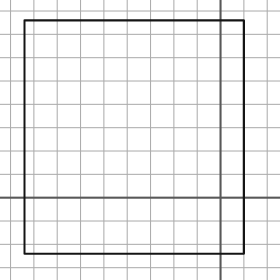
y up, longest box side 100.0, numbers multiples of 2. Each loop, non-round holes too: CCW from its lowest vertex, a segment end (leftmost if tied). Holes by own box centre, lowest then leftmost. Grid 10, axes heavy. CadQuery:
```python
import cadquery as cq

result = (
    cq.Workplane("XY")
    .moveTo(-84.0, -24.0)
    .lineTo(10.0, -24.0)
    .lineTo(10.0, 76.0)
    .lineTo(-84.0, 76.0)
    .close()
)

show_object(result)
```